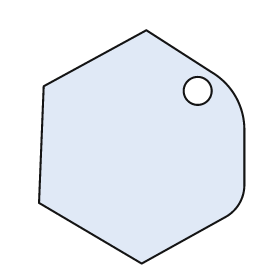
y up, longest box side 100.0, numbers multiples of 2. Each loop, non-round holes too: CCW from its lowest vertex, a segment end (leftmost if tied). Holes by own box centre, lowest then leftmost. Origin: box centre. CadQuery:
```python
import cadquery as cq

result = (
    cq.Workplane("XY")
    .moveTo(0.0, -50.0)
    .lineTo(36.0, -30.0)
    .threePointArc((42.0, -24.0), (44.0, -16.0))
    .lineTo(44.0, 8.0)
    .threePointArc((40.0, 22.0), (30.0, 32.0))
    .lineTo(2.0, 50.0)
    .lineTo(-42.0, 26.0)
    .lineTo(-44.0, -24.0)
    .close()
    .moveTo(24.0, 24.0)
    .circle(6.0)
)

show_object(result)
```